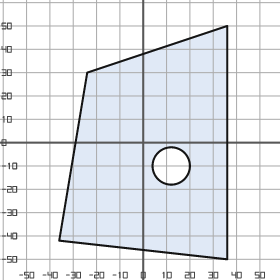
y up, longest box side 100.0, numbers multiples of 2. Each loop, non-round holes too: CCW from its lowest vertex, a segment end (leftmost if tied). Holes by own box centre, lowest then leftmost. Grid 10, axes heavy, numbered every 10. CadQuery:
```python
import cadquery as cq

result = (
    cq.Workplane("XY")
    .moveTo(36.0, -50.0)
    .lineTo(36.0, 50.0)
    .lineTo(-24.0, 30.0)
    .lineTo(-36.0, -42.0)
    .close()
    .moveTo(12.0, -10.0)
    .circle(8.0)
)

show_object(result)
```